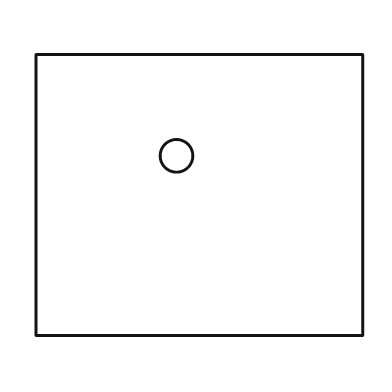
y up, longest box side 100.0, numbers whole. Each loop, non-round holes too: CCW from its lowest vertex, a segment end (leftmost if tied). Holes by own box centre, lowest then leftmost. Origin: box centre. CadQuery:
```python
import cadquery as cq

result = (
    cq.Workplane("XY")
    .moveTo(-50.0, -43.0)
    .lineTo(50.0, -43.0)
    .lineTo(50.0, 43.0)
    .lineTo(-50.0, 43.0)
    .close()
    .moveTo(-7.0, 12.0)
    .circle(5.0)
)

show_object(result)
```